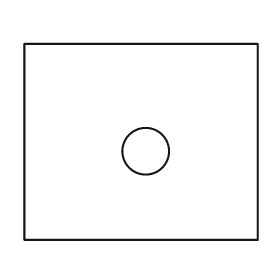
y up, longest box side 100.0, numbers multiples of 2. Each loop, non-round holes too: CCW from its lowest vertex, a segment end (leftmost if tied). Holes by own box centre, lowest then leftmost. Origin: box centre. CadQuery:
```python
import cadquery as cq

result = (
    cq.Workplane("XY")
    .moveTo(-50.0, -42.0)
    .lineTo(50.0, -42.0)
    .lineTo(50.0, 42.0)
    .lineTo(-50.0, 42.0)
    .close()
    .moveTo(2.0, -4.0)
    .circle(10.0)
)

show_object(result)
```